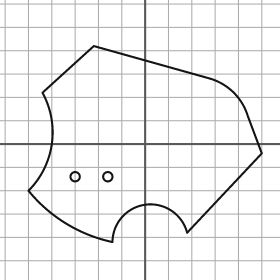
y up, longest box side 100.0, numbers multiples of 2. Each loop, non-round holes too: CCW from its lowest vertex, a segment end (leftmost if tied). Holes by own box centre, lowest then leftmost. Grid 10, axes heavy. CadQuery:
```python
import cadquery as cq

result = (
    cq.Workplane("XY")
    .moveTo(-14.0, -42.0)
    .threePointArc((0.0, -26.0), (18.0, -38.0))
    .lineTo(50.0, -4.0)
    .lineTo(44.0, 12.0)
    .threePointArc((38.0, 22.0), (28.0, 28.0))
    .lineTo(-22.0, 42.0)
    .lineTo(-44.0, 22.0)
    .threePointArc((-40.0, 0.0), (-50.0, -20.0))
    .threePointArc((-34.0, -34.0), (-14.0, -42.0))
    .close()
    .moveTo(-30.0, -14.0)
    .circle(2.0)
    .moveTo(-16.0, -14.0)
    .circle(2.0)
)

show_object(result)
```